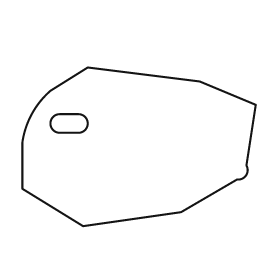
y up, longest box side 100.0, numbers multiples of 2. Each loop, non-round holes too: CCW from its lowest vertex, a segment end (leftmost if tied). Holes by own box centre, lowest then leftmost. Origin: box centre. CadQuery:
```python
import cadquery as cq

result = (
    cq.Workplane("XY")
    .moveTo(-24.0, -34.0)
    .lineTo(18.0, -28.0)
    .lineTo(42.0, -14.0)
    .threePointArc((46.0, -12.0), (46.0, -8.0))
    .lineTo(50.0, 18.0)
    .lineTo(26.0, 28.0)
    .lineTo(-22.0, 34.0)
    .lineTo(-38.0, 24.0)
    .threePointArc((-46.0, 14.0), (-50.0, 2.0))
    .lineTo(-50.0, -18.0)
    .close()
    .moveTo(-34.0, 6.0)
    .lineTo(-26.0, 6.0)
    .threePointArc((-22.0, 10.0), (-26.0, 14.0))
    .lineTo(-34.0, 14.0)
    .threePointArc((-38.0, 10.0), (-34.0, 6.0))
    .close()
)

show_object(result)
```